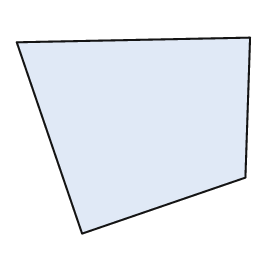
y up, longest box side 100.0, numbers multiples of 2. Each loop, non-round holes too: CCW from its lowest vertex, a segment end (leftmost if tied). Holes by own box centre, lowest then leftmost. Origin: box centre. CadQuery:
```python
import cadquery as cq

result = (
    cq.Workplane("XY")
    .moveTo(-22.0, -42.0)
    .lineTo(48.0, -18.0)
    .lineTo(50.0, 42.0)
    .lineTo(-50.0, 40.0)
    .close()
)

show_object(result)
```